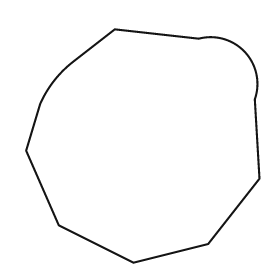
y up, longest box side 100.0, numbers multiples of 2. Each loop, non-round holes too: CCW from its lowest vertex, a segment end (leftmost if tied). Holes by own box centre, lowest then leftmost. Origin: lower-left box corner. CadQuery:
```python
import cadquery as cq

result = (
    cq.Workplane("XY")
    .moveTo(46.0, 0.0)
    .lineTo(78.0, 8.0)
    .lineTo(100.0, 36.0)
    .lineTo(98.0, 70.0)
    .threePointArc((94.0, 90.0), (74.0, 96.0))
    .lineTo(38.0, 100.0)
    .lineTo(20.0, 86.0)
    .threePointArc((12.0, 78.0), (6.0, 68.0))
    .lineTo(0.0, 48.0)
    .lineTo(14.0, 16.0)
    .close()
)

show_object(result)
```